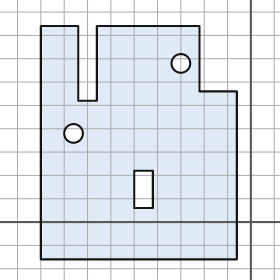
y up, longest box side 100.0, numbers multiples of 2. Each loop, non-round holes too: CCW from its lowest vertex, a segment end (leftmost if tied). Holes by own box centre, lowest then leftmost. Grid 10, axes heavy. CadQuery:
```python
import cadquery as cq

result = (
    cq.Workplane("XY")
    .moveTo(-90.0, -16.0)
    .lineTo(-6.0, -16.0)
    .lineTo(-6.0, 56.0)
    .lineTo(-22.0, 56.0)
    .lineTo(-22.0, 84.0)
    .lineTo(-66.0, 84.0)
    .lineTo(-66.0, 52.0)
    .lineTo(-74.0, 52.0)
    .lineTo(-74.0, 84.0)
    .lineTo(-90.0, 84.0)
    .close()
    .moveTo(-50.0, 6.0)
    .lineTo(-42.0, 6.0)
    .lineTo(-42.0, 22.0)
    .lineTo(-50.0, 22.0)
    .close()
    .moveTo(-76.0, 38.0)
    .circle(4.0)
    .moveTo(-30.0, 68.0)
    .circle(4.0)
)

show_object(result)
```